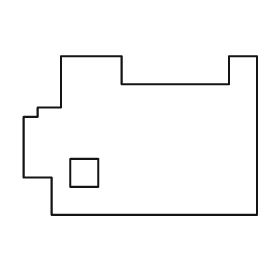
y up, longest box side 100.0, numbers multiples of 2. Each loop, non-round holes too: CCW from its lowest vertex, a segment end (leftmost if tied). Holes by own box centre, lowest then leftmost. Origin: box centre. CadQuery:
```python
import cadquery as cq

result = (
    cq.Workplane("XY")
    .moveTo(-38.0, -34.0)
    .lineTo(50.0, -34.0)
    .lineTo(50.0, 34.0)
    .lineTo(38.0, 34.0)
    .lineTo(38.0, 22.0)
    .lineTo(-8.0, 22.0)
    .lineTo(-8.0, 34.0)
    .lineTo(-34.0, 34.0)
    .lineTo(-34.0, 12.0)
    .lineTo(-44.0, 12.0)
    .lineTo(-44.0, 8.0)
    .lineTo(-50.0, 8.0)
    .lineTo(-50.0, -18.0)
    .lineTo(-38.0, -18.0)
    .close()
    .moveTo(-30.0, -22.0)
    .lineTo(-18.0, -22.0)
    .lineTo(-18.0, -10.0)
    .lineTo(-30.0, -10.0)
    .close()
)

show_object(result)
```